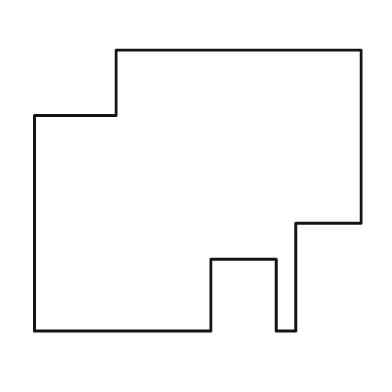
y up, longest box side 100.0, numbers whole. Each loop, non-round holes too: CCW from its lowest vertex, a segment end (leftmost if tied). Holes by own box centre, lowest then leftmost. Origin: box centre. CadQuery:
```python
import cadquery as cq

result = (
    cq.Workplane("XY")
    .moveTo(-50.0, -43.0)
    .lineTo(4.0, -43.0)
    .lineTo(4.0, -21.0)
    .lineTo(24.0, -21.0)
    .lineTo(24.0, -43.0)
    .lineTo(30.0, -43.0)
    .lineTo(30.0, -10.0)
    .lineTo(50.0, -10.0)
    .lineTo(50.0, 43.0)
    .lineTo(-25.0, 43.0)
    .lineTo(-25.0, 23.0)
    .lineTo(-50.0, 23.0)
    .close()
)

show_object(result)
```